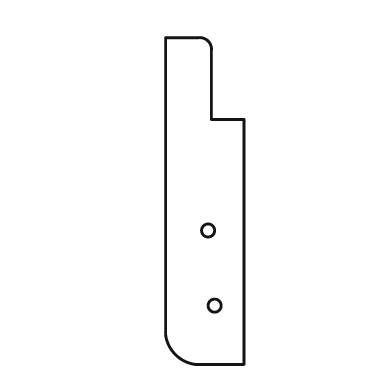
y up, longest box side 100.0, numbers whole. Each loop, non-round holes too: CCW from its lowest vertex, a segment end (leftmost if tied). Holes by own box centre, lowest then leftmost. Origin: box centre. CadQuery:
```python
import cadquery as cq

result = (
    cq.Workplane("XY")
    .moveTo(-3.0, -50.0)
    .lineTo(12.0, -50.0)
    .lineTo(12.0, 25.0)
    .lineTo(2.0, 25.0)
    .lineTo(2.0, 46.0)
    .threePointArc((1.0, 49.0), (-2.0, 50.0))
    .lineTo(-12.0, 50.0)
    .lineTo(-12.0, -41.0)
    .threePointArc((-9.0, -47.0), (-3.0, -50.0))
    .close()
    .moveTo(3.0, -32.0)
    .circle(2.0)
    .moveTo(1.0, -9.0)
    .circle(2.0)
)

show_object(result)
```